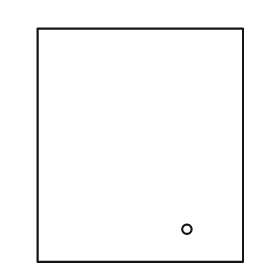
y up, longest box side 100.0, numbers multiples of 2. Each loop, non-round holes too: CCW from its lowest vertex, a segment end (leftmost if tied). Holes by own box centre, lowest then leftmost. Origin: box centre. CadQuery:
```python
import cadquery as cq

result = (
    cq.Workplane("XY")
    .moveTo(-44.0, -50.0)
    .lineTo(44.0, -50.0)
    .lineTo(44.0, 50.0)
    .lineTo(-44.0, 50.0)
    .close()
    .moveTo(20.0, -36.0)
    .circle(2.0)
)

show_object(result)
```